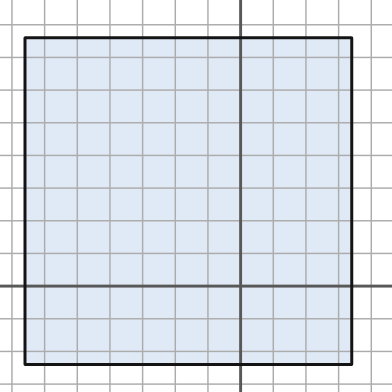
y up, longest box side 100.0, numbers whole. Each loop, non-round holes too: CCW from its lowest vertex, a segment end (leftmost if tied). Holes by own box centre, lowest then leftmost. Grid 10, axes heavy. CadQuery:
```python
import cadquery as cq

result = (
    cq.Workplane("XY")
    .moveTo(-66.0, -24.0)
    .lineTo(34.0, -24.0)
    .lineTo(34.0, 76.0)
    .lineTo(-66.0, 76.0)
    .close()
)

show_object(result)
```